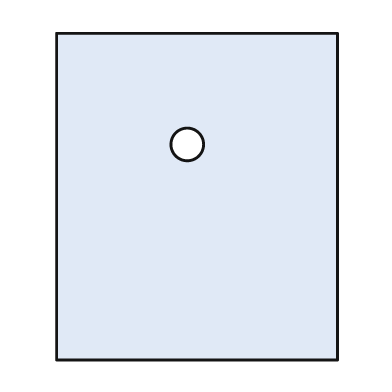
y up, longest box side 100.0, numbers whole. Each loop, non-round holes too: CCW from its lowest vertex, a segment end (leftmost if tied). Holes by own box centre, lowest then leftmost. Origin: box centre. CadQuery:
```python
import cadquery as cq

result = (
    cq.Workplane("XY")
    .moveTo(-43.0, -50.0)
    .lineTo(43.0, -50.0)
    .lineTo(43.0, 50.0)
    .lineTo(-43.0, 50.0)
    .close()
    .moveTo(-3.0, 16.0)
    .circle(5.0)
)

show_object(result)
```